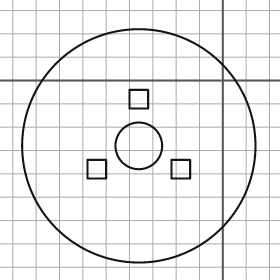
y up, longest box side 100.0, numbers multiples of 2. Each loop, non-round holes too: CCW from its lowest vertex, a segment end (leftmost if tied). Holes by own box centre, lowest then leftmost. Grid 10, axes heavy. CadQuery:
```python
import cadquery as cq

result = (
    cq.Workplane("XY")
    .moveTo(-36.0, -28.0)
    .circle(50.0)
    .moveTo(-58.0, -42.0)
    .lineTo(-50.0, -42.0)
    .lineTo(-50.0, -34.0)
    .lineTo(-58.0, -34.0)
    .close()
    .moveTo(-22.0, -42.0)
    .lineTo(-14.0, -42.0)
    .lineTo(-14.0, -34.0)
    .lineTo(-22.0, -34.0)
    .close()
    .moveTo(-36.0, -28.0)
    .circle(10.0)
    .moveTo(-40.0, -12.0)
    .lineTo(-32.0, -12.0)
    .lineTo(-32.0, -4.0)
    .lineTo(-40.0, -4.0)
    .close()
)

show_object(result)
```